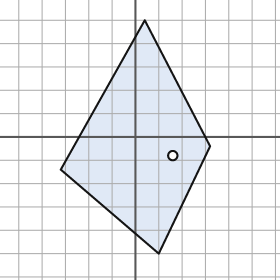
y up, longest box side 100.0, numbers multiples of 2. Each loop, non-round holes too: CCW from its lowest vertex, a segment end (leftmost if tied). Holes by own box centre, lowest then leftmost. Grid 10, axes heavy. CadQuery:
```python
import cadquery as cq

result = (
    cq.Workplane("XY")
    .moveTo(10.0, -50.0)
    .lineTo(32.0, -4.0)
    .lineTo(4.0, 50.0)
    .lineTo(-32.0, -14.0)
    .close()
    .moveTo(16.0, -8.0)
    .circle(2.0)
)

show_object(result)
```